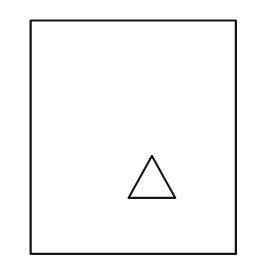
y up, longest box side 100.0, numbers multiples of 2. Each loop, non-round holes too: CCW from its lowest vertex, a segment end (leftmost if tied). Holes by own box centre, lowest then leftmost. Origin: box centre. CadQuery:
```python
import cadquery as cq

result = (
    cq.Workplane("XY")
    .moveTo(-44.0, -50.0)
    .lineTo(44.0, -50.0)
    .lineTo(44.0, 50.0)
    .lineTo(-44.0, 50.0)
    .close()
    .moveTo(-2.0, -26.0)
    .lineTo(18.0, -26.0)
    .lineTo(8.0, -8.0)
    .close()
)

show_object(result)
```